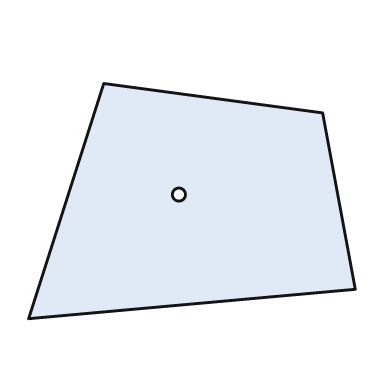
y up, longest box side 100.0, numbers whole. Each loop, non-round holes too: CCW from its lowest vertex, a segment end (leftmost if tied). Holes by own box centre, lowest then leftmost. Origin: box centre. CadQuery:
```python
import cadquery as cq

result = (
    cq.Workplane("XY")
    .moveTo(-50.0, -36.0)
    .lineTo(50.0, -27.0)
    .lineTo(40.0, 27.0)
    .lineTo(-27.0, 36.0)
    .close()
    .moveTo(-4.0, 2.0)
    .circle(2.0)
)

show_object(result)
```